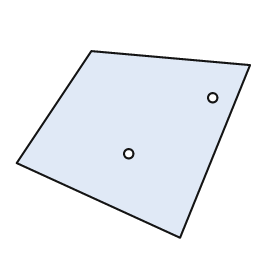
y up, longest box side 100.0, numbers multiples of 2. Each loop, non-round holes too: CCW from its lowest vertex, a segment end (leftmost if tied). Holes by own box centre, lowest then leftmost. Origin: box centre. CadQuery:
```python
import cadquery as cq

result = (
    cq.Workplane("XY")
    .moveTo(20.0, -40.0)
    .lineTo(50.0, 34.0)
    .lineTo(-18.0, 40.0)
    .lineTo(-50.0, -8.0)
    .close()
    .moveTo(-2.0, -4.0)
    .circle(2.0)
    .moveTo(34.0, 20.0)
    .circle(2.0)
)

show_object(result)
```